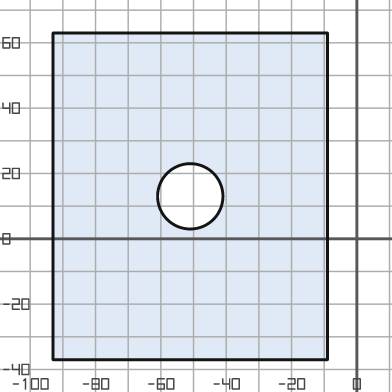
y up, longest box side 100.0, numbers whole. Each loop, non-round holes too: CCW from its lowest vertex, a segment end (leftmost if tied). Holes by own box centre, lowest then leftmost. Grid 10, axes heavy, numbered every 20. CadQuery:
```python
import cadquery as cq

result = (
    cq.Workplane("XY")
    .moveTo(-93.0, -37.0)
    .lineTo(-9.0, -37.0)
    .lineTo(-9.0, 63.0)
    .lineTo(-93.0, 63.0)
    .close()
    .moveTo(-51.0, 13.0)
    .circle(10.0)
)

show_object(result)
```